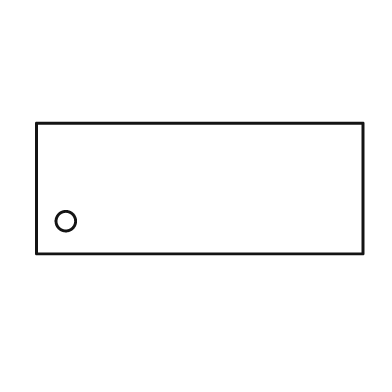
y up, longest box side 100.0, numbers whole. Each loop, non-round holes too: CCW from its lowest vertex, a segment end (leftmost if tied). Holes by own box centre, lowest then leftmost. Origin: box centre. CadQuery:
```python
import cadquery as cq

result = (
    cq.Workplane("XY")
    .moveTo(-50.0, -20.0)
    .lineTo(50.0, -20.0)
    .lineTo(50.0, 20.0)
    .lineTo(-50.0, 20.0)
    .close()
    .moveTo(-41.0, -10.0)
    .circle(3.0)
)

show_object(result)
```